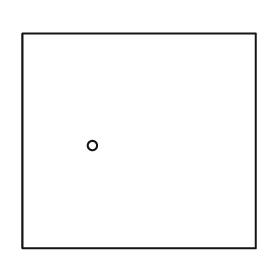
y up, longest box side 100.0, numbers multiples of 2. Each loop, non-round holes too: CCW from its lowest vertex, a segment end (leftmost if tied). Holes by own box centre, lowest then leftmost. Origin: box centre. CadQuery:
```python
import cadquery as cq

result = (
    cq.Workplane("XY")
    .moveTo(-50.0, -46.0)
    .lineTo(50.0, -46.0)
    .lineTo(50.0, 46.0)
    .lineTo(-50.0, 46.0)
    .close()
    .moveTo(-20.0, -2.0)
    .circle(2.0)
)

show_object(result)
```